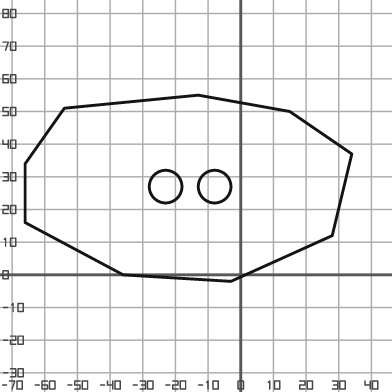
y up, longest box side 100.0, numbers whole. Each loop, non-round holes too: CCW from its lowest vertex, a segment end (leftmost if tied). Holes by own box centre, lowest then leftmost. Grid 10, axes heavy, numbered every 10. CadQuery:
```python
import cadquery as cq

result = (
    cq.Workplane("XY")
    .moveTo(-3.0, -2.0)
    .lineTo(28.0, 12.0)
    .lineTo(34.0, 37.0)
    .lineTo(15.0, 50.0)
    .lineTo(-13.0, 55.0)
    .lineTo(-54.0, 51.0)
    .lineTo(-66.0, 34.0)
    .lineTo(-66.0, 16.0)
    .lineTo(-36.0, 0.0)
    .close()
    .moveTo(-23.0, 27.0)
    .circle(5.0)
    .moveTo(-8.0, 27.0)
    .circle(5.0)
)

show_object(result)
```